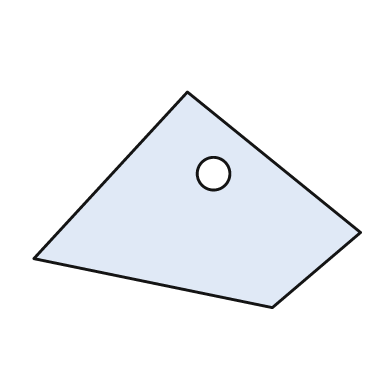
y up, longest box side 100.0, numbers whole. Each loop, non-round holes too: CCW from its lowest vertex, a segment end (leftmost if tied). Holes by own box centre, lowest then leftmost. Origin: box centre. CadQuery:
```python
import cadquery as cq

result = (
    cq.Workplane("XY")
    .moveTo(23.0, -33.0)
    .lineTo(50.0, -10.0)
    .lineTo(-3.0, 33.0)
    .lineTo(-50.0, -18.0)
    .close()
    .moveTo(5.0, 8.0)
    .circle(5.0)
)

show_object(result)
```